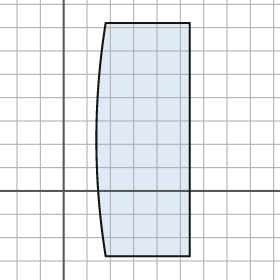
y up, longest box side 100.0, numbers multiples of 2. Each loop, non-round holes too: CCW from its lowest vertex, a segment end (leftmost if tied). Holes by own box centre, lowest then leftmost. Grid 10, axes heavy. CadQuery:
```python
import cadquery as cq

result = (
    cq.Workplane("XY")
    .moveTo(18.0, -28.0)
    .lineTo(54.0, -28.0)
    .lineTo(54.0, 72.0)
    .lineTo(18.0, 72.0)
    .threePointArc((14.0, 22.0), (18.0, -28.0))
    .close()
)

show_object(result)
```